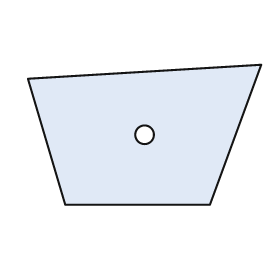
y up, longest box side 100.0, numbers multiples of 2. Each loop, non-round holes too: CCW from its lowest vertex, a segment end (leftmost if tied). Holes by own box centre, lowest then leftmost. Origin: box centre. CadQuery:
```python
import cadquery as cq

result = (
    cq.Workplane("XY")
    .moveTo(-34.0, -30.0)
    .lineTo(28.0, -30.0)
    .lineTo(50.0, 30.0)
    .lineTo(-50.0, 24.0)
    .close()
    .moveTo(0.0, 0.0)
    .circle(4.0)
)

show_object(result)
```